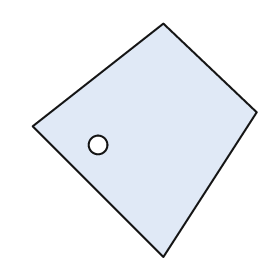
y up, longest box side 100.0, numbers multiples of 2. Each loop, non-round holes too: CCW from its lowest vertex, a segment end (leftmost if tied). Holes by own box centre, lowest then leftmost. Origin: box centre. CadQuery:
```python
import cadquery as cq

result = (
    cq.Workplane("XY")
    .moveTo(8.0, -50.0)
    .lineTo(48.0, 12.0)
    .lineTo(8.0, 50.0)
    .lineTo(-48.0, 6.0)
    .close()
    .moveTo(-20.0, -2.0)
    .circle(4.0)
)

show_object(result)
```